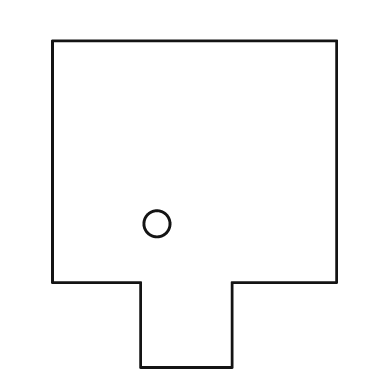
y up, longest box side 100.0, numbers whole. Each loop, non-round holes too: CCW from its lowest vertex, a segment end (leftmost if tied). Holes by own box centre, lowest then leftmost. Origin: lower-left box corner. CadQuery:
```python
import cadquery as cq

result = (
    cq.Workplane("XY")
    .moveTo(27.0, 0.0)
    .lineTo(55.0, 0.0)
    .lineTo(55.0, 26.0)
    .lineTo(87.0, 26.0)
    .lineTo(87.0, 100.0)
    .lineTo(0.0, 100.0)
    .lineTo(0.0, 26.0)
    .lineTo(27.0, 26.0)
    .close()
    .moveTo(32.0, 44.0)
    .circle(4.0)
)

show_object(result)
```